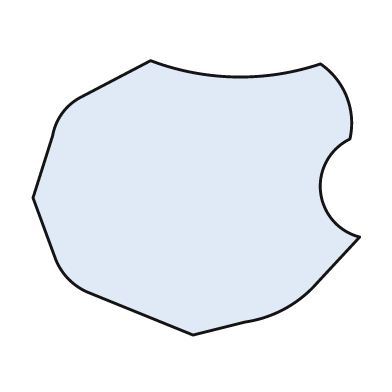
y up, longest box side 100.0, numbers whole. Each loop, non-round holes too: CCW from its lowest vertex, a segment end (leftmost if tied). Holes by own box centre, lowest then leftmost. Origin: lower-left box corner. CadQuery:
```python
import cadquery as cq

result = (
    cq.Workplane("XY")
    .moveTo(49.0, 0.0)
    .lineTo(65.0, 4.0)
    .threePointArc((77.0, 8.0), (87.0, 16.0))
    .lineTo(100.0, 30.0)
    .threePointArc((88.0, 44.0), (97.0, 60.0))
    .threePointArc((96.0, 73.0), (88.0, 83.0))
    .threePointArc((62.0, 79.0), (36.0, 84.0))
    .lineTo(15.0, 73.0)
    .threePointArc((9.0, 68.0), (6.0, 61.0))
    .lineTo(0.0, 42.0)
    .lineTo(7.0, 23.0)
    .threePointArc((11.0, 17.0), (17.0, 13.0))
    .close()
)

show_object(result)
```